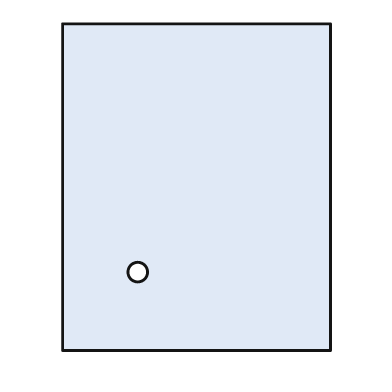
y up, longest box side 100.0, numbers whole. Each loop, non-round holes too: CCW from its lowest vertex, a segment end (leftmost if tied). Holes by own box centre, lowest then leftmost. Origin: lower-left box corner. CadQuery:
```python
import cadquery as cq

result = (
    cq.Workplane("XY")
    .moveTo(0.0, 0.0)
    .lineTo(82.0, 0.0)
    .lineTo(82.0, 100.0)
    .lineTo(0.0, 100.0)
    .close()
    .moveTo(23.0, 24.0)
    .circle(3.0)
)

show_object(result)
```